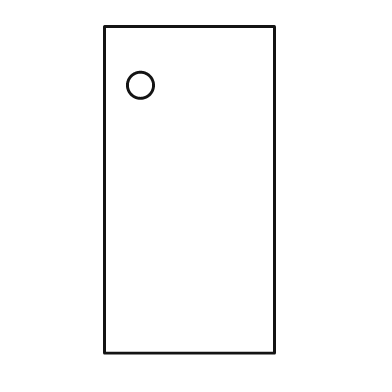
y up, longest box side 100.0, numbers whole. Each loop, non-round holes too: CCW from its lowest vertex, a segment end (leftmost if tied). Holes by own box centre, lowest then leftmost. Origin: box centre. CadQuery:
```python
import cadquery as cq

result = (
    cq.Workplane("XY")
    .moveTo(-26.0, -50.0)
    .lineTo(26.0, -50.0)
    .lineTo(26.0, 50.0)
    .lineTo(-26.0, 50.0)
    .close()
    .moveTo(-15.0, 32.0)
    .circle(4.0)
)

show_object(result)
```